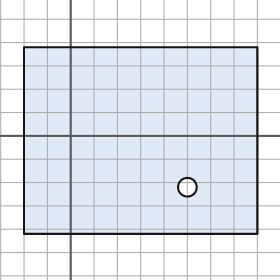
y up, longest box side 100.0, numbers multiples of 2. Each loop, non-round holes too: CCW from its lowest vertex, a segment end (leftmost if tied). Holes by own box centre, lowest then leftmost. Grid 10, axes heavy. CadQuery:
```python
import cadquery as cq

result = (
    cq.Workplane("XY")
    .moveTo(-20.0, -42.0)
    .lineTo(80.0, -42.0)
    .lineTo(80.0, 38.0)
    .lineTo(-20.0, 38.0)
    .close()
    .moveTo(50.0, -22.0)
    .circle(4.0)
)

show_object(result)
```